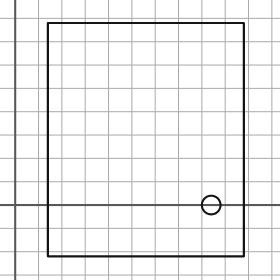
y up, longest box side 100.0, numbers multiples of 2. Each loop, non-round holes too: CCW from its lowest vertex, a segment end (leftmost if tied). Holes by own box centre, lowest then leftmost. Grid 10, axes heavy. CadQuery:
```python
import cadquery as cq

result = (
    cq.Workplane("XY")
    .moveTo(14.0, -22.0)
    .lineTo(98.0, -22.0)
    .lineTo(98.0, 78.0)
    .lineTo(14.0, 78.0)
    .close()
    .moveTo(84.0, 0.0)
    .circle(4.0)
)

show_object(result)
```